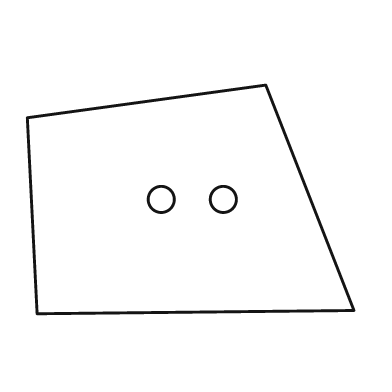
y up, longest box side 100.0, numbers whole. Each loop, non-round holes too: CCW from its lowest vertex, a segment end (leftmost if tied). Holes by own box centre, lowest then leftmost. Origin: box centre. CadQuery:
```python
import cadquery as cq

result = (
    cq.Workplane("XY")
    .moveTo(-47.0, -35.0)
    .lineTo(50.0, -34.0)
    .lineTo(23.0, 35.0)
    .lineTo(-50.0, 25.0)
    .close()
    .moveTo(-9.0, 0.0)
    .circle(4.0)
    .moveTo(10.0, 0.0)
    .circle(4.0)
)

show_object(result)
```